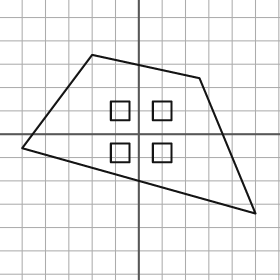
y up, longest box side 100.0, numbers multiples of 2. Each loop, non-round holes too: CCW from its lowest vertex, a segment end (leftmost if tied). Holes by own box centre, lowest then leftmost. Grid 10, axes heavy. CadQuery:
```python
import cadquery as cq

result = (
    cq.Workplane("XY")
    .moveTo(50.0, -34.0)
    .lineTo(26.0, 24.0)
    .lineTo(-20.0, 34.0)
    .lineTo(-50.0, -6.0)
    .close()
    .moveTo(-12.0, -12.0)
    .lineTo(-4.0, -12.0)
    .lineTo(-4.0, -4.0)
    .lineTo(-12.0, -4.0)
    .close()
    .moveTo(6.0, -12.0)
    .lineTo(14.0, -12.0)
    .lineTo(14.0, -4.0)
    .lineTo(6.0, -4.0)
    .close()
    .moveTo(-12.0, 6.0)
    .lineTo(-4.0, 6.0)
    .lineTo(-4.0, 14.0)
    .lineTo(-12.0, 14.0)
    .close()
    .moveTo(6.0, 6.0)
    .lineTo(14.0, 6.0)
    .lineTo(14.0, 14.0)
    .lineTo(6.0, 14.0)
    .close()
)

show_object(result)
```